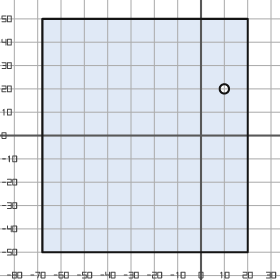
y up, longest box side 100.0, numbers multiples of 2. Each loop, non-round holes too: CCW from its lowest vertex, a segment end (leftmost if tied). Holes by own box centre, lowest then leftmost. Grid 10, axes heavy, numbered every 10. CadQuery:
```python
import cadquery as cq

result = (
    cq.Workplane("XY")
    .moveTo(-68.0, -50.0)
    .lineTo(20.0, -50.0)
    .lineTo(20.0, 50.0)
    .lineTo(-68.0, 50.0)
    .close()
    .moveTo(10.0, 20.0)
    .circle(2.0)
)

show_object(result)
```